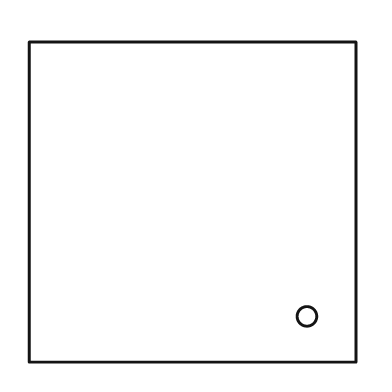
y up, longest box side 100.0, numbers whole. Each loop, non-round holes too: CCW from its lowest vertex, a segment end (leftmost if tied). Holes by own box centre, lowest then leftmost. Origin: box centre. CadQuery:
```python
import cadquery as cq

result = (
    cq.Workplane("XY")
    .moveTo(-50.0, -49.0)
    .lineTo(50.0, -49.0)
    .lineTo(50.0, 49.0)
    .lineTo(-50.0, 49.0)
    .close()
    .moveTo(35.0, -35.0)
    .circle(3.0)
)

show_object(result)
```